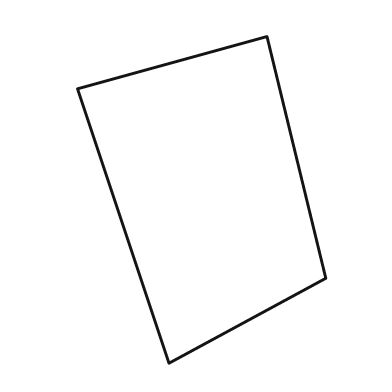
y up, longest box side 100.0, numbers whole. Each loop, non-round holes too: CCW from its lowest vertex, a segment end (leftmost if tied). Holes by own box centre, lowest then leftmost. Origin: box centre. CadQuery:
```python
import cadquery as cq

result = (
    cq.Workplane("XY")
    .moveTo(-10.0, -50.0)
    .lineTo(38.0, -24.0)
    .lineTo(20.0, 50.0)
    .lineTo(-38.0, 34.0)
    .close()
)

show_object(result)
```